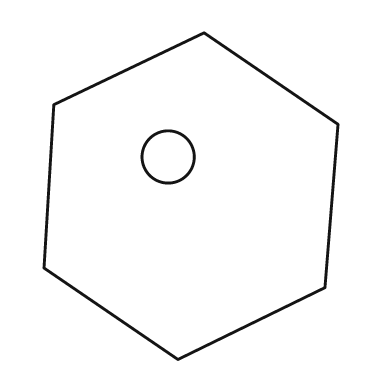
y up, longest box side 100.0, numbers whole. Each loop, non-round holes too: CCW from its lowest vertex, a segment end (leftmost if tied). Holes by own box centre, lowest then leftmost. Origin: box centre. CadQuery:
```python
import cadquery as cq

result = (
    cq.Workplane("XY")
    .moveTo(-4.0, -50.0)
    .lineTo(41.0, -28.0)
    .lineTo(45.0, 22.0)
    .lineTo(4.0, 50.0)
    .lineTo(-42.0, 28.0)
    .lineTo(-45.0, -22.0)
    .close()
    .moveTo(-7.0, 12.0)
    .circle(8.0)
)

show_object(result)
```